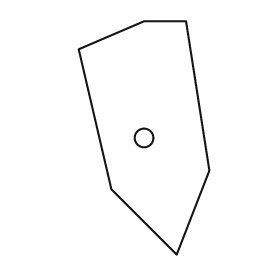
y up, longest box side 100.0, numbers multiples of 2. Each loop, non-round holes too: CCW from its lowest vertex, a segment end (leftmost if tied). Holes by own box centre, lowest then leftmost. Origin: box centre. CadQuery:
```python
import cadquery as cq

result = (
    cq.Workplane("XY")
    .moveTo(14.0, -50.0)
    .lineTo(28.0, -14.0)
    .lineTo(18.0, 50.0)
    .lineTo(0.0, 50.0)
    .lineTo(-28.0, 38.0)
    .lineTo(-14.0, -22.0)
    .close()
    .moveTo(0.0, 0.0)
    .circle(4.0)
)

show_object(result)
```